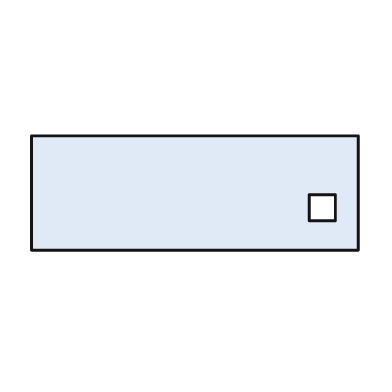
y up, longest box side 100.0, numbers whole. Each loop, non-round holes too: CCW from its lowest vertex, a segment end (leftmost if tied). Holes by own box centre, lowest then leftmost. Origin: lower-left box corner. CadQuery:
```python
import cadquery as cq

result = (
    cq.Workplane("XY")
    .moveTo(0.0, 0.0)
    .lineTo(100.0, 0.0)
    .lineTo(100.0, 35.0)
    .lineTo(0.0, 35.0)
    .close()
    .moveTo(85.0, 9.0)
    .lineTo(93.0, 9.0)
    .lineTo(93.0, 17.0)
    .lineTo(85.0, 17.0)
    .close()
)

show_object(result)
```